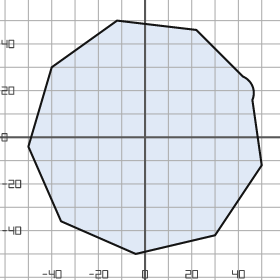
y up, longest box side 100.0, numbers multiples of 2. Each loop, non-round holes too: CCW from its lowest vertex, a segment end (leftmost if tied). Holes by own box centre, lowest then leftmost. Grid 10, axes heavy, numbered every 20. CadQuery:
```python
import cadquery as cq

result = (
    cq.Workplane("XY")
    .moveTo(-4.0, -50.0)
    .lineTo(30.0, -42.0)
    .lineTo(50.0, -12.0)
    .lineTo(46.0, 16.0)
    .threePointArc((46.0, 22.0), (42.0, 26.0))
    .lineTo(22.0, 46.0)
    .lineTo(-12.0, 50.0)
    .lineTo(-40.0, 30.0)
    .lineTo(-50.0, -4.0)
    .lineTo(-36.0, -36.0)
    .close()
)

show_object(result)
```